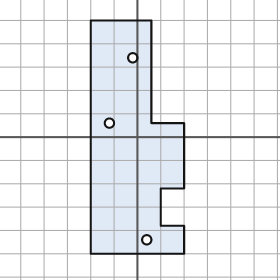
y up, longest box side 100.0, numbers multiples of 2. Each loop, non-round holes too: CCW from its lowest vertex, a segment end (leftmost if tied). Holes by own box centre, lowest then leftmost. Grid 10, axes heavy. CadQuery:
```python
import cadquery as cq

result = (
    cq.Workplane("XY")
    .moveTo(-20.0, -50.0)
    .lineTo(20.0, -50.0)
    .lineTo(20.0, -38.0)
    .lineTo(10.0, -38.0)
    .lineTo(10.0, -22.0)
    .lineTo(20.0, -22.0)
    .lineTo(20.0, 6.0)
    .lineTo(6.0, 6.0)
    .lineTo(6.0, 50.0)
    .lineTo(-20.0, 50.0)
    .close()
    .moveTo(4.0, -44.0)
    .circle(2.0)
    .moveTo(-12.0, 6.0)
    .circle(2.0)
    .moveTo(-2.0, 34.0)
    .circle(2.0)
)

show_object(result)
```